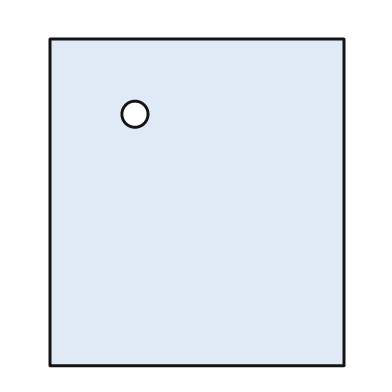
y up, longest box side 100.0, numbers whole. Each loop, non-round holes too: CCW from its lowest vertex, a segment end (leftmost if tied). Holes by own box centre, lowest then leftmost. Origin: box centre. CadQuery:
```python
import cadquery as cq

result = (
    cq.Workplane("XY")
    .moveTo(-45.0, -50.0)
    .lineTo(45.0, -50.0)
    .lineTo(45.0, 50.0)
    .lineTo(-45.0, 50.0)
    .close()
    .moveTo(-19.0, 27.0)
    .circle(4.0)
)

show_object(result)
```